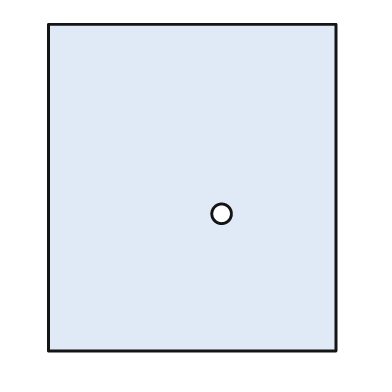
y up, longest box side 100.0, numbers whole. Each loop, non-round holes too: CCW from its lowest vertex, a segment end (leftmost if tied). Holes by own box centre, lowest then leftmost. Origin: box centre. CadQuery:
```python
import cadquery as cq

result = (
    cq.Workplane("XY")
    .moveTo(-44.0, -50.0)
    .lineTo(44.0, -50.0)
    .lineTo(44.0, 50.0)
    .lineTo(-44.0, 50.0)
    .close()
    .moveTo(9.0, -8.0)
    .circle(3.0)
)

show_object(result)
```